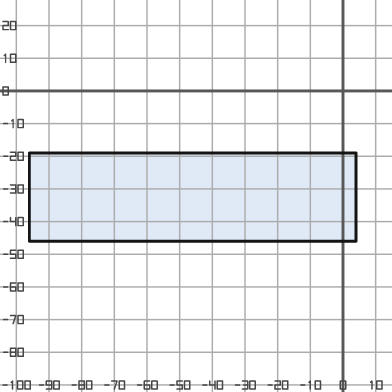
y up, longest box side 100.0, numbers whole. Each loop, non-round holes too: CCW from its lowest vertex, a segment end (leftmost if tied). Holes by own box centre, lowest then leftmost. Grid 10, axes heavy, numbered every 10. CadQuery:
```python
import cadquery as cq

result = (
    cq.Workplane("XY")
    .moveTo(-96.0, -46.0)
    .lineTo(4.0, -46.0)
    .lineTo(4.0, -19.0)
    .lineTo(-96.0, -19.0)
    .close()
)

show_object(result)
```